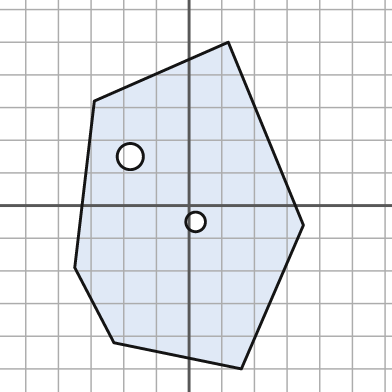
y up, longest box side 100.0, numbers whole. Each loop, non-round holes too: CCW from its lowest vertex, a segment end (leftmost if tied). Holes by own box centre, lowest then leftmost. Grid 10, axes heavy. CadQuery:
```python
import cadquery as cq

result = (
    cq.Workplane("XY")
    .moveTo(16.0, -50.0)
    .lineTo(35.0, -6.0)
    .lineTo(12.0, 50.0)
    .lineTo(-29.0, 32.0)
    .lineTo(-35.0, -19.0)
    .lineTo(-23.0, -42.0)
    .close()
    .moveTo(2.0, -5.0)
    .circle(3.0)
    .moveTo(-18.0, 15.0)
    .circle(4.0)
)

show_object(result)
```